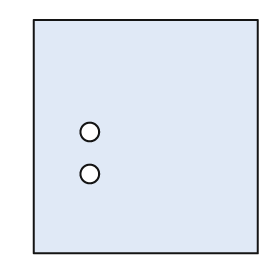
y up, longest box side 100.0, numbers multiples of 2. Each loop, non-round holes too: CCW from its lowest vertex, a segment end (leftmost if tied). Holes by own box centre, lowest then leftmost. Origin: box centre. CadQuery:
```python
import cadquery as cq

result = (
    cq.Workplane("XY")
    .moveTo(-48.0, -50.0)
    .lineTo(48.0, -50.0)
    .lineTo(48.0, 50.0)
    .lineTo(-48.0, 50.0)
    .close()
    .moveTo(-24.0, -16.0)
    .circle(4.0)
    .moveTo(-24.0, 2.0)
    .circle(4.0)
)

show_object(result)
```